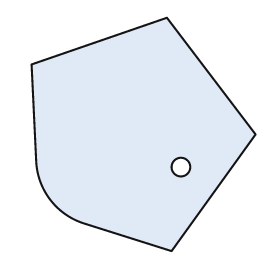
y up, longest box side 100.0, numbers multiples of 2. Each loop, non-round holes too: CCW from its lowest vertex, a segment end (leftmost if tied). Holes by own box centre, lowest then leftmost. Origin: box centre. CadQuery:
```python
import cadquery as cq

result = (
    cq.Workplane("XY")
    .moveTo(12.0, -50.0)
    .lineTo(48.0, 0.0)
    .lineTo(10.0, 50.0)
    .lineTo(-48.0, 30.0)
    .lineTo(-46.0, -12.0)
    .threePointArc((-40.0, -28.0), (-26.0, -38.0))
    .close()
    .moveTo(16.0, -14.0)
    .circle(4.0)
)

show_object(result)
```